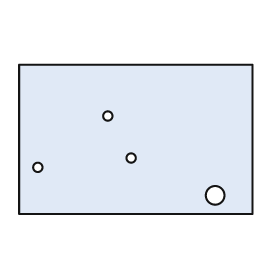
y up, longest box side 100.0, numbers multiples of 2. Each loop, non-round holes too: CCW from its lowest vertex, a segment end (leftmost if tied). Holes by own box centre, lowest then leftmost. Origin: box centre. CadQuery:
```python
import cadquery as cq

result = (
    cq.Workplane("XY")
    .moveTo(-50.0, -32.0)
    .lineTo(50.0, -32.0)
    .lineTo(50.0, 32.0)
    .lineTo(-50.0, 32.0)
    .close()
    .moveTo(34.0, -24.0)
    .circle(4.0)
    .moveTo(-42.0, -12.0)
    .circle(2.0)
    .moveTo(-2.0, -8.0)
    .circle(2.0)
    .moveTo(-12.0, 10.0)
    .circle(2.0)
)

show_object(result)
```